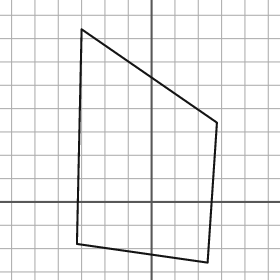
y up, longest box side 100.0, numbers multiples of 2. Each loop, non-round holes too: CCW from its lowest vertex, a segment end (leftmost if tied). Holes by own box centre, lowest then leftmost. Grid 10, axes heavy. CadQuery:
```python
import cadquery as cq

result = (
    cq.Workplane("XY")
    .moveTo(24.0, -26.0)
    .lineTo(28.0, 34.0)
    .lineTo(-30.0, 74.0)
    .lineTo(-32.0, -18.0)
    .close()
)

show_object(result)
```